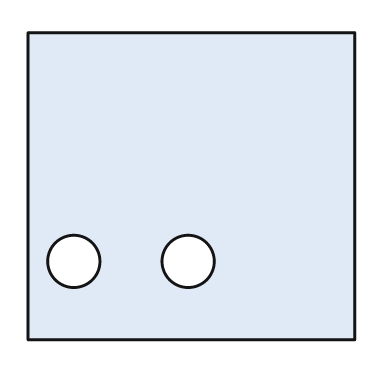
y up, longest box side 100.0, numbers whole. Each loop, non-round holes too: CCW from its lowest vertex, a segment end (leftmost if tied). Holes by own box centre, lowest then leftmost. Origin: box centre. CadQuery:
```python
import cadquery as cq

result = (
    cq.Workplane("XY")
    .moveTo(-50.0, -47.0)
    .lineTo(50.0, -47.0)
    .lineTo(50.0, 47.0)
    .lineTo(-50.0, 47.0)
    .close()
    .moveTo(-36.0, -23.0)
    .circle(8.0)
    .moveTo(-1.0, -23.0)
    .circle(8.0)
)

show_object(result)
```